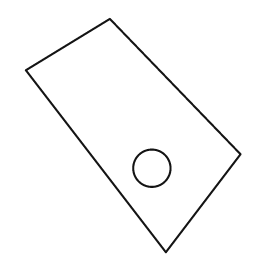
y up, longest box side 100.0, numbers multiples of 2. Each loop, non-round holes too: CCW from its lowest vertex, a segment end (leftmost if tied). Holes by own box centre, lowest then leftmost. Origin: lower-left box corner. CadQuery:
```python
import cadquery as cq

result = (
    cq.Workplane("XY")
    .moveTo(60.0, 0.0)
    .lineTo(92.0, 42.0)
    .lineTo(36.0, 100.0)
    .lineTo(0.0, 78.0)
    .close()
    .moveTo(54.0, 36.0)
    .circle(8.0)
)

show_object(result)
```